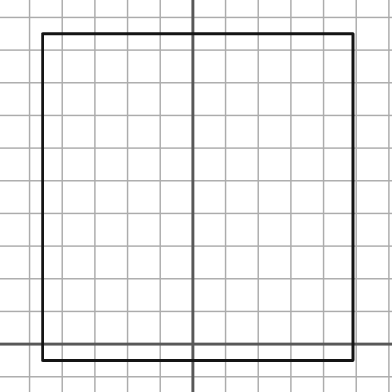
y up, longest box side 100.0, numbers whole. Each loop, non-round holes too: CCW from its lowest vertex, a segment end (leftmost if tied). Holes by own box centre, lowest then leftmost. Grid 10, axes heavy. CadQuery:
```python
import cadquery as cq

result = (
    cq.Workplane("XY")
    .moveTo(-46.0, -5.0)
    .lineTo(49.0, -5.0)
    .lineTo(49.0, 95.0)
    .lineTo(-46.0, 95.0)
    .close()
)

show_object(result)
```